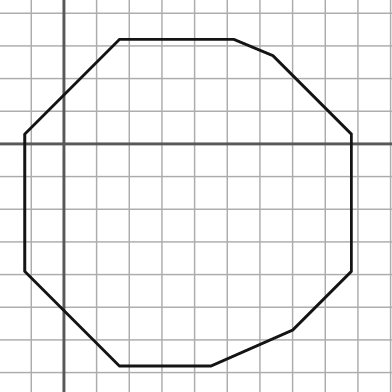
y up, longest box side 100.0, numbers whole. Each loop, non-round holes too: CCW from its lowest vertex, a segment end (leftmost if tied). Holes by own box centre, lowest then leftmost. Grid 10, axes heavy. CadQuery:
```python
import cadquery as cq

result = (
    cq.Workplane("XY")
    .moveTo(17.0, -68.0)
    .lineTo(45.0, -68.0)
    .lineTo(70.0, -57.0)
    .lineTo(88.0, -39.0)
    .lineTo(88.0, 3.0)
    .lineTo(64.0, 27.0)
    .lineTo(52.0, 32.0)
    .lineTo(17.0, 32.0)
    .lineTo(-12.0, 3.0)
    .lineTo(-12.0, -39.0)
    .close()
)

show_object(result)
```